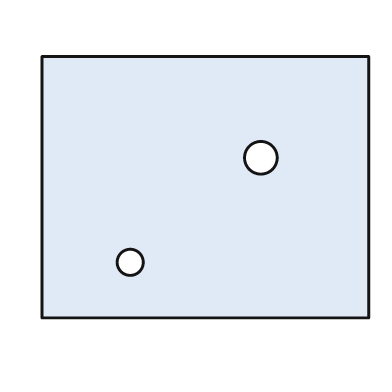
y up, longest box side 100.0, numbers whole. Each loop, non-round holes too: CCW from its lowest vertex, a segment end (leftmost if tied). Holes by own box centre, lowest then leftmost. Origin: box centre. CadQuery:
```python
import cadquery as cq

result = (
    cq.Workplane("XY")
    .moveTo(-50.0, -40.0)
    .lineTo(50.0, -40.0)
    .lineTo(50.0, 40.0)
    .lineTo(-50.0, 40.0)
    .close()
    .moveTo(-23.0, -23.0)
    .circle(4.0)
    .moveTo(17.0, 9.0)
    .circle(5.0)
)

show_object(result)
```